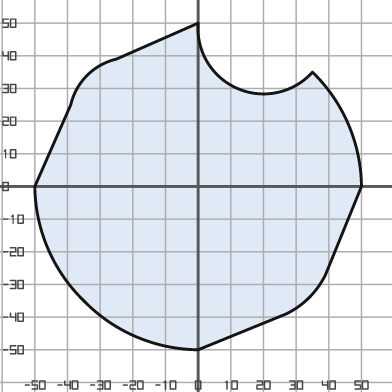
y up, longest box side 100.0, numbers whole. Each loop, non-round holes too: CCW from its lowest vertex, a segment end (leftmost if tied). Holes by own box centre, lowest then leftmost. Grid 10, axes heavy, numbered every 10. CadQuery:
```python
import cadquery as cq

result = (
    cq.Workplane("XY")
    .moveTo(0.0, -50.0)
    .lineTo(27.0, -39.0)
    .threePointArc((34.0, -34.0), (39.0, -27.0))
    .lineTo(50.0, 0.0)
    .threePointArc((46.0, 19.0), (35.0, 35.0))
    .threePointArc((12.0, 30.0), (0.0, 50.0))
    .lineTo(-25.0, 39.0)
    .threePointArc((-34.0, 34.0), (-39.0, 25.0))
    .lineTo(-50.0, 0.0)
    .threePointArc((-46.0, -19.0), (-35.0, -35.0))
    .threePointArc((-19.0, -46.0), (0.0, -50.0))
    .close()
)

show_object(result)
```